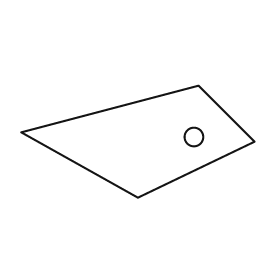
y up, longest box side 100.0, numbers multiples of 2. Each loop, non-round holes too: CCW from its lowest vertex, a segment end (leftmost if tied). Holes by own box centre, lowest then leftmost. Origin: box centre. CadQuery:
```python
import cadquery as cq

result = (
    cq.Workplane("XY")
    .moveTo(0.0, -24.0)
    .lineTo(50.0, 0.0)
    .lineTo(26.0, 24.0)
    .lineTo(-50.0, 4.0)
    .close()
    .moveTo(24.0, 2.0)
    .circle(4.0)
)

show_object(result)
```